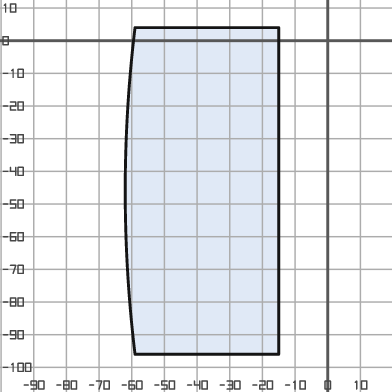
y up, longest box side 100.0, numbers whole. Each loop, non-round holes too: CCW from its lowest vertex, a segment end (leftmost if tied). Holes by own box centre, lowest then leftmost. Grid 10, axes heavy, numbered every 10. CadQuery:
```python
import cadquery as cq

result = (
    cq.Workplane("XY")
    .moveTo(-59.0, -96.0)
    .lineTo(-15.0, -96.0)
    .lineTo(-15.0, 4.0)
    .lineTo(-59.0, 4.0)
    .threePointArc((-62.0, -46.0), (-59.0, -96.0))
    .close()
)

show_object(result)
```